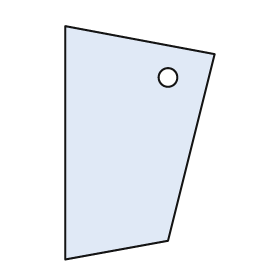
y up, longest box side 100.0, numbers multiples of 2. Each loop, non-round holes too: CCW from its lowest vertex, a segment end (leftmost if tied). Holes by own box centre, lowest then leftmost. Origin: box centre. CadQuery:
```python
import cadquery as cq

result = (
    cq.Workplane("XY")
    .moveTo(-32.0, -50.0)
    .lineTo(12.0, -42.0)
    .lineTo(32.0, 38.0)
    .lineTo(-32.0, 50.0)
    .close()
    .moveTo(12.0, 28.0)
    .circle(4.0)
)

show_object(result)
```